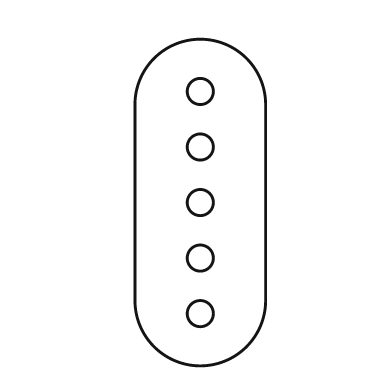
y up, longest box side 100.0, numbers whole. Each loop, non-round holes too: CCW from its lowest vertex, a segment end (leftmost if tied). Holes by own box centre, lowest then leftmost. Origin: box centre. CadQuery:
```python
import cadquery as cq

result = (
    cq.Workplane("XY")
    .moveTo(-20.0, -30.0)
    .threePointArc((0.0, -50.0), (20.0, -30.0))
    .lineTo(20.0, 30.0)
    .threePointArc((0.0, 50.0), (-20.0, 30.0))
    .close()
    .moveTo(0.0, -34.0)
    .circle(4.0)
    .moveTo(0.0, -17.0)
    .circle(4.0)
    .moveTo(0.0, 0.0)
    .circle(4.0)
    .moveTo(0.0, 17.0)
    .circle(4.0)
    .moveTo(0.0, 34.0)
    .circle(4.0)
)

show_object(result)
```